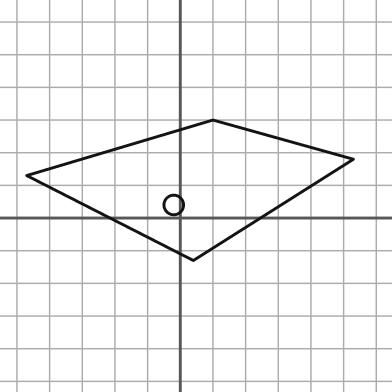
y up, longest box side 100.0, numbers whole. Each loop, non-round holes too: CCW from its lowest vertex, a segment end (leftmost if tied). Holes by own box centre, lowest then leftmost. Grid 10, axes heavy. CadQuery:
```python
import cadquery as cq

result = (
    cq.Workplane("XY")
    .moveTo(4.0, -13.0)
    .lineTo(53.0, 18.0)
    .lineTo(10.0, 30.0)
    .lineTo(-47.0, 13.0)
    .close()
    .moveTo(-2.0, 4.0)
    .circle(3.0)
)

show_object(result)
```